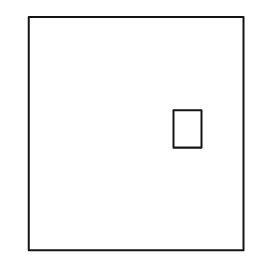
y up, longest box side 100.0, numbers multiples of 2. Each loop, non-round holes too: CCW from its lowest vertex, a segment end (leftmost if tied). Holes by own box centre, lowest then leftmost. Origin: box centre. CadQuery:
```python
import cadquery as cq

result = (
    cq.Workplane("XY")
    .moveTo(-46.0, -50.0)
    .lineTo(46.0, -50.0)
    .lineTo(46.0, 50.0)
    .lineTo(-46.0, 50.0)
    .close()
    .moveTo(16.0, -6.0)
    .lineTo(28.0, -6.0)
    .lineTo(28.0, 10.0)
    .lineTo(16.0, 10.0)
    .close()
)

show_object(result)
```